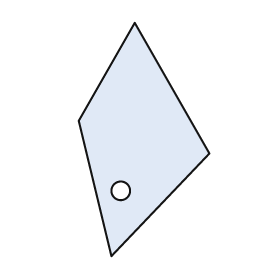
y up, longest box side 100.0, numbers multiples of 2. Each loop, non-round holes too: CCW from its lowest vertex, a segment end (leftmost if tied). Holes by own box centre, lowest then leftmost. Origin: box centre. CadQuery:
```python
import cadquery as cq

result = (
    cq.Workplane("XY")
    .moveTo(-14.0, -50.0)
    .lineTo(28.0, -6.0)
    .lineTo(-4.0, 50.0)
    .lineTo(-28.0, 8.0)
    .close()
    .moveTo(-10.0, -22.0)
    .circle(4.0)
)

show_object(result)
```